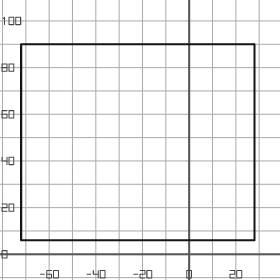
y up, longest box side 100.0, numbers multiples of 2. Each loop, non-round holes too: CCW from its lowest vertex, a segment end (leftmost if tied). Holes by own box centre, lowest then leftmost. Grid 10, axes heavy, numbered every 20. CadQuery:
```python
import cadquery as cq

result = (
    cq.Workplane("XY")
    .moveTo(-72.0, 6.0)
    .lineTo(28.0, 6.0)
    .lineTo(28.0, 90.0)
    .lineTo(-72.0, 90.0)
    .close()
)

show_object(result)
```